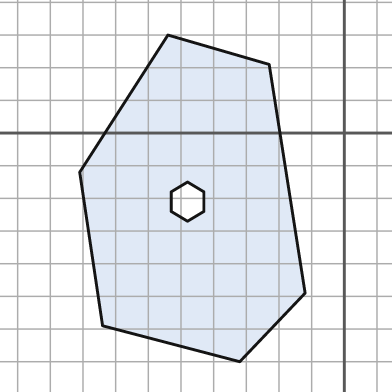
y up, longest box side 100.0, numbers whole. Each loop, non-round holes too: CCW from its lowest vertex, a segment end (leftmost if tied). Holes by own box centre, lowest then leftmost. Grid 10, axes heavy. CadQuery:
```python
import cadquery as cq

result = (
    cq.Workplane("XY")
    .moveTo(-32.0, -70.0)
    .lineTo(-12.0, -49.0)
    .lineTo(-23.0, 21.0)
    .lineTo(-54.0, 30.0)
    .lineTo(-81.0, -12.0)
    .lineTo(-74.0, -59.0)
    .close()
    .moveTo(-48.0, -27.0)
    .lineTo(-43.0, -24.0)
    .lineTo(-43.0, -18.0)
    .lineTo(-48.0, -15.0)
    .lineTo(-53.0, -18.0)
    .lineTo(-53.0, -24.0)
    .close()
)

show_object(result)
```